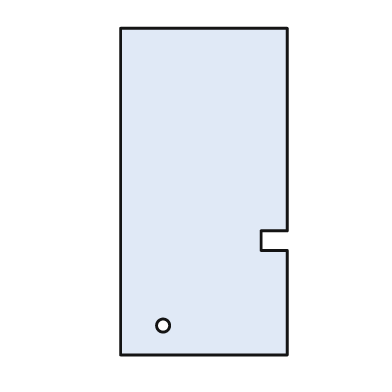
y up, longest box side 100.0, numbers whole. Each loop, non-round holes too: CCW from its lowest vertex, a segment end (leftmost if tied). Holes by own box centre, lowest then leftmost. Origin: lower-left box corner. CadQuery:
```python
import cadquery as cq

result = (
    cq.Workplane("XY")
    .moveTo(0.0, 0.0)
    .lineTo(51.0, 0.0)
    .lineTo(51.0, 32.0)
    .lineTo(43.0, 32.0)
    .lineTo(43.0, 38.0)
    .lineTo(51.0, 38.0)
    .lineTo(51.0, 100.0)
    .lineTo(0.0, 100.0)
    .close()
    .moveTo(13.0, 9.0)
    .circle(2.0)
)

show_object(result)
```